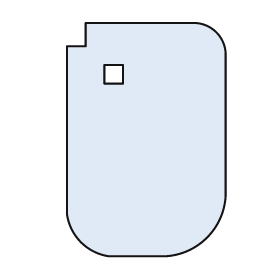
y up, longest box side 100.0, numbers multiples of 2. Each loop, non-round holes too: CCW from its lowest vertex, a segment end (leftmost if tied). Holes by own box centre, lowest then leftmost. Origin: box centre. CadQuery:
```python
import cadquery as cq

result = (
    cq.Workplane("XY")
    .moveTo(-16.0, -50.0)
    .lineTo(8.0, -50.0)
    .threePointArc((26.0, -42.0), (34.0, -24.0))
    .lineTo(34.0, 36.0)
    .threePointArc((30.0, 46.0), (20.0, 50.0))
    .lineTo(-26.0, 50.0)
    .lineTo(-26.0, 40.0)
    .lineTo(-34.0, 40.0)
    .lineTo(-34.0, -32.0)
    .threePointArc((-28.0, -44.0), (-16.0, -50.0))
    .close()
    .moveTo(-18.0, 24.0)
    .lineTo(-10.0, 24.0)
    .lineTo(-10.0, 32.0)
    .lineTo(-18.0, 32.0)
    .close()
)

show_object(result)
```